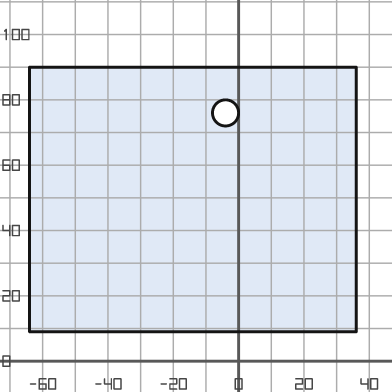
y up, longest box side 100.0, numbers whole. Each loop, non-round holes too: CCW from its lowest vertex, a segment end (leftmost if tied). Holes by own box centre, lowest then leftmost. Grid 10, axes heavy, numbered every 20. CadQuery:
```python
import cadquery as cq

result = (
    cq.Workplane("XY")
    .moveTo(-64.0, 9.0)
    .lineTo(36.0, 9.0)
    .lineTo(36.0, 90.0)
    .lineTo(-64.0, 90.0)
    .close()
    .moveTo(-4.0, 76.0)
    .circle(4.0)
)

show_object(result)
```